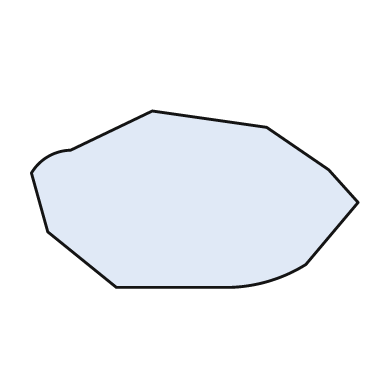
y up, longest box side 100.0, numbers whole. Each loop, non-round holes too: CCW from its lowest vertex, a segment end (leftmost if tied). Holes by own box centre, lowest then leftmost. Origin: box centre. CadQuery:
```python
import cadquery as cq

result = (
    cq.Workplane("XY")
    .moveTo(-24.0, -27.0)
    .lineTo(11.0, -27.0)
    .threePointArc((23.0, -25.0), (34.0, -20.0))
    .lineTo(50.0, -1.0)
    .lineTo(41.0, 9.0)
    .lineTo(22.0, 22.0)
    .lineTo(-13.0, 27.0)
    .lineTo(-38.0, 15.0)
    .threePointArc((-45.0, 13.0), (-50.0, 8.0))
    .lineTo(-45.0, -10.0)
    .close()
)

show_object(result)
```